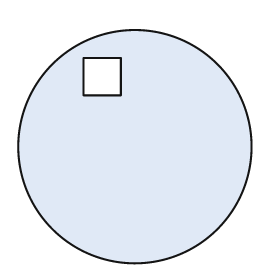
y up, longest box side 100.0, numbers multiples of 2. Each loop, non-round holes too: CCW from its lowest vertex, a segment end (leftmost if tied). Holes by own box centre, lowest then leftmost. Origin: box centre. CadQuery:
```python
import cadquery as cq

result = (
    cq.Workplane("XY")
    .moveTo(0.0, 0.0)
    .circle(50.0)
    .moveTo(-22.0, 22.0)
    .lineTo(-6.0, 22.0)
    .lineTo(-6.0, 38.0)
    .lineTo(-22.0, 38.0)
    .close()
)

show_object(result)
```